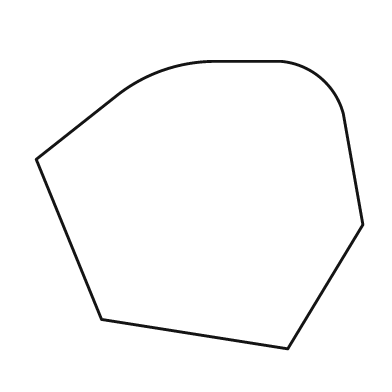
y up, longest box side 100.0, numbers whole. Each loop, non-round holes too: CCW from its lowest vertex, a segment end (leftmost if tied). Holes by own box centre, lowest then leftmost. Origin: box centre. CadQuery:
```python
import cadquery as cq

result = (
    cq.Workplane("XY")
    .moveTo(27.0, -44.0)
    .lineTo(50.0, -6.0)
    .lineTo(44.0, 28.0)
    .threePointArc((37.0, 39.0), (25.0, 44.0))
    .lineTo(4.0, 44.0)
    .threePointArc((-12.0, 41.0), (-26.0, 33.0))
    .lineTo(-50.0, 14.0)
    .lineTo(-30.0, -35.0)
    .close()
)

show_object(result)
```